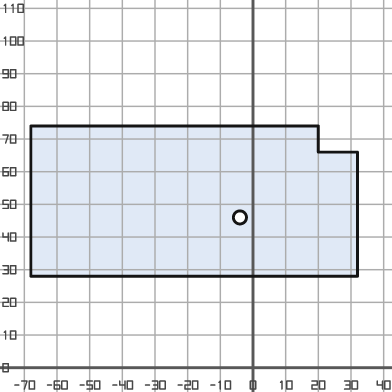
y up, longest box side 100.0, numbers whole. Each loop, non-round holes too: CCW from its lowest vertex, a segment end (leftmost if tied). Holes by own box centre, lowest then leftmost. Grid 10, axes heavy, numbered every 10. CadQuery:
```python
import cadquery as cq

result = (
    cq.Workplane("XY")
    .moveTo(-68.0, 28.0)
    .lineTo(32.0, 28.0)
    .lineTo(32.0, 66.0)
    .lineTo(20.0, 66.0)
    .lineTo(20.0, 74.0)
    .lineTo(-68.0, 74.0)
    .close()
    .moveTo(-4.0, 46.0)
    .circle(2.0)
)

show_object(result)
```